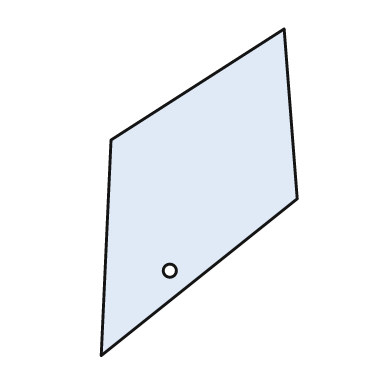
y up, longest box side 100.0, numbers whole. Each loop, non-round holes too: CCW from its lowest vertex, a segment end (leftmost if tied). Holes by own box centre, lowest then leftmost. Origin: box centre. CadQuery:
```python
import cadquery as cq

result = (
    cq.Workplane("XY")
    .moveTo(-30.0, -50.0)
    .lineTo(30.0, -2.0)
    .lineTo(26.0, 50.0)
    .lineTo(-27.0, 16.0)
    .close()
    .moveTo(-9.0, -24.0)
    .circle(2.0)
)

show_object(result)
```